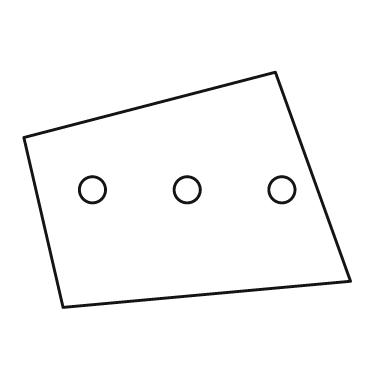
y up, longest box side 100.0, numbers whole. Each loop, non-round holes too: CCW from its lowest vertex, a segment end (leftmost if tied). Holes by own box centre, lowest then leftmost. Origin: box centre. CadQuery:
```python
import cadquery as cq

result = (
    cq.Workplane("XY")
    .moveTo(-38.0, -36.0)
    .lineTo(50.0, -28.0)
    .lineTo(27.0, 36.0)
    .lineTo(-50.0, 16.0)
    .close()
    .moveTo(-29.0, 0.0)
    .circle(4.0)
    .moveTo(0.0, 0.0)
    .circle(4.0)
    .moveTo(29.0, 0.0)
    .circle(4.0)
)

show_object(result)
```